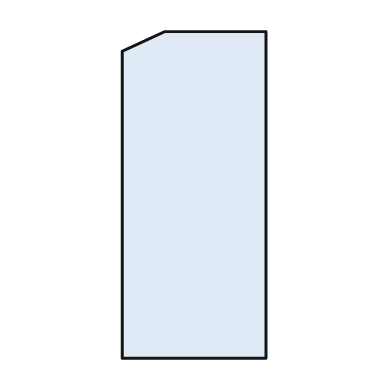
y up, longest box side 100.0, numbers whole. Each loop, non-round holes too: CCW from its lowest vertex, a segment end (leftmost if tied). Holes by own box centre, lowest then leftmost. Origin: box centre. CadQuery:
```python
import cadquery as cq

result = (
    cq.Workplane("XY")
    .moveTo(-22.0, -50.0)
    .lineTo(22.0, -50.0)
    .lineTo(22.0, 50.0)
    .lineTo(-9.0, 50.0)
    .lineTo(-22.0, 44.0)
    .close()
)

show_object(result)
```